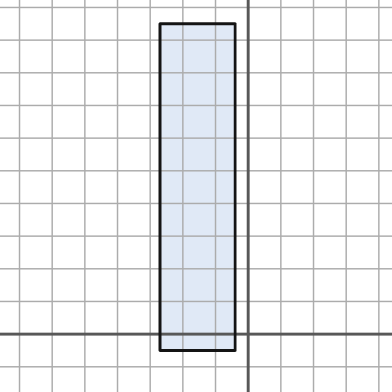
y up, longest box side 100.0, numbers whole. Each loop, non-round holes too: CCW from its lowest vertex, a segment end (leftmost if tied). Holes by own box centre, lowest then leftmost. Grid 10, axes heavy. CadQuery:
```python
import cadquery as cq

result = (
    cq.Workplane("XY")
    .moveTo(-27.0, -5.0)
    .lineTo(-4.0, -5.0)
    .lineTo(-4.0, 95.0)
    .lineTo(-27.0, 95.0)
    .close()
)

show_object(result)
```